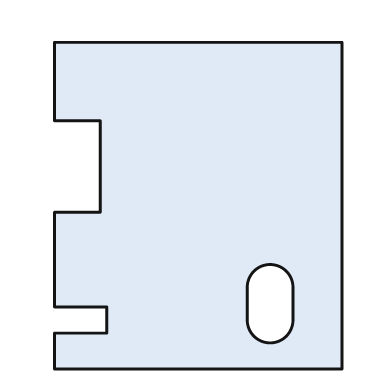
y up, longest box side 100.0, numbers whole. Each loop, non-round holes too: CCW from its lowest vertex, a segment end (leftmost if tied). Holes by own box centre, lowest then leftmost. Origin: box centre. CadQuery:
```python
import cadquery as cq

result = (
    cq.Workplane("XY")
    .moveTo(-44.0, -50.0)
    .lineTo(44.0, -50.0)
    .lineTo(44.0, 50.0)
    .lineTo(-44.0, 50.0)
    .lineTo(-44.0, 26.0)
    .lineTo(-30.0, 26.0)
    .lineTo(-30.0, -2.0)
    .lineTo(-44.0, -2.0)
    .lineTo(-44.0, -31.0)
    .lineTo(-28.0, -31.0)
    .lineTo(-28.0, -39.0)
    .lineTo(-44.0, -39.0)
    .close()
    .moveTo(15.0, -35.0)
    .threePointArc((22.0, -42.0), (29.0, -35.0))
    .lineTo(29.0, -25.0)
    .threePointArc((22.0, -18.0), (15.0, -25.0))
    .close()
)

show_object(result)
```